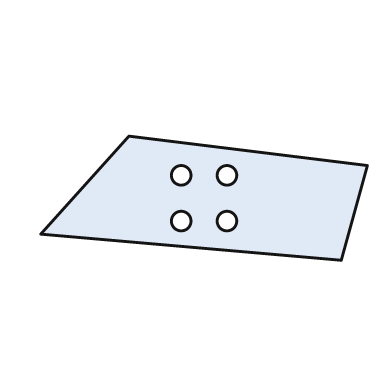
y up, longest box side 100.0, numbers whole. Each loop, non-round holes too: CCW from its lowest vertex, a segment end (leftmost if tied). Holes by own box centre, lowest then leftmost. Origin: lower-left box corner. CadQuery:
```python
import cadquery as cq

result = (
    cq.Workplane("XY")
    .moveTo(92.0, 0.0)
    .lineTo(100.0, 29.0)
    .lineTo(27.0, 38.0)
    .lineTo(0.0, 8.0)
    .close()
    .moveTo(43.0, 12.0)
    .circle(3.0)
    .moveTo(57.0, 12.0)
    .circle(3.0)
    .moveTo(43.0, 26.0)
    .circle(3.0)
    .moveTo(57.0, 26.0)
    .circle(3.0)
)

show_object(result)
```